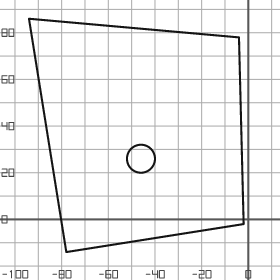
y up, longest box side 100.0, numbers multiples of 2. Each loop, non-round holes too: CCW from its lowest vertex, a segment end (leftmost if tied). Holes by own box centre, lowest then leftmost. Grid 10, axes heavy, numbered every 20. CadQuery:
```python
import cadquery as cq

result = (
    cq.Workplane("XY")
    .moveTo(-78.0, -14.0)
    .lineTo(-2.0, -2.0)
    .lineTo(-4.0, 78.0)
    .lineTo(-94.0, 86.0)
    .close()
    .moveTo(-46.0, 26.0)
    .circle(6.0)
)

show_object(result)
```